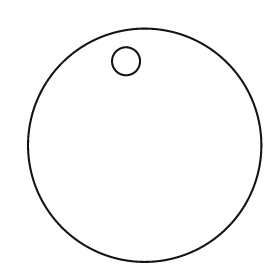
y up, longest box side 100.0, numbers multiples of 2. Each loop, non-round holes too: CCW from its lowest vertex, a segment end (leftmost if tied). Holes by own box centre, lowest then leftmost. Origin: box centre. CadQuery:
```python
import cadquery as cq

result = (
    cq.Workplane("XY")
    .moveTo(0.0, 0.0)
    .circle(50.0)
    .moveTo(-8.0, 36.0)
    .circle(6.0)
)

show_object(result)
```